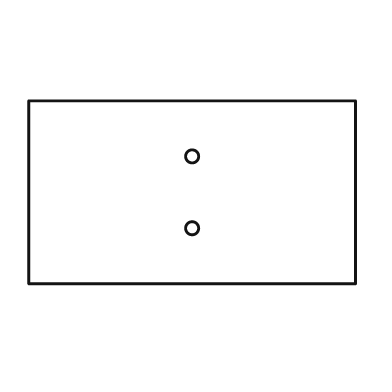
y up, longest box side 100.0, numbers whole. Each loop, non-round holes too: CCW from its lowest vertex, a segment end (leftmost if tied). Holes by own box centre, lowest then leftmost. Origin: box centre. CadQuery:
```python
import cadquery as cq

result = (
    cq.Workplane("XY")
    .moveTo(-50.0, -28.0)
    .lineTo(50.0, -28.0)
    .lineTo(50.0, 28.0)
    .lineTo(-50.0, 28.0)
    .close()
    .moveTo(0.0, -11.0)
    .circle(2.0)
    .moveTo(0.0, 11.0)
    .circle(2.0)
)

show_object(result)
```